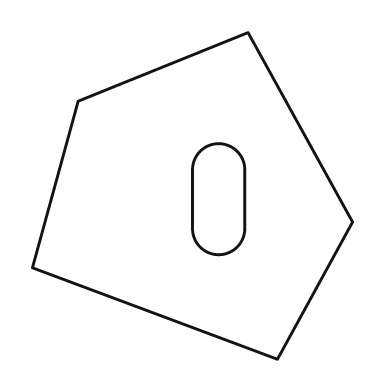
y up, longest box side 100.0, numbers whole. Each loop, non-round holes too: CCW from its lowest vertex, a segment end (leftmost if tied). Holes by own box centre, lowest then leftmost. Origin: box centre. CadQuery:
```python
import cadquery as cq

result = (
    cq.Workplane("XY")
    .moveTo(26.0, -50.0)
    .lineTo(49.0, -8.0)
    .lineTo(17.0, 50.0)
    .lineTo(-35.0, 29.0)
    .lineTo(-49.0, -22.0)
    .close()
    .moveTo(0.0, -10.0)
    .threePointArc((8.0, -18.0), (16.0, -10.0))
    .lineTo(16.0, 8.0)
    .threePointArc((8.0, 16.0), (0.0, 8.0))
    .close()
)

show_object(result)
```